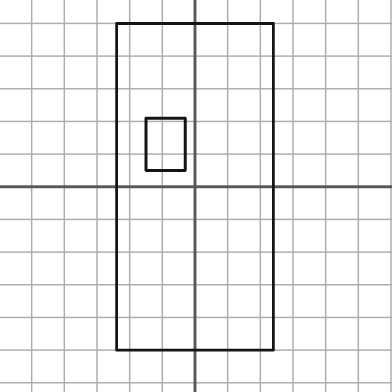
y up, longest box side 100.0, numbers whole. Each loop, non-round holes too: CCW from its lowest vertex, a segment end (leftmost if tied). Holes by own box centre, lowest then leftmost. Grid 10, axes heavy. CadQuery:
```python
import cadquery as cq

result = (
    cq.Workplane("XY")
    .moveTo(-24.0, -50.0)
    .lineTo(24.0, -50.0)
    .lineTo(24.0, 50.0)
    .lineTo(-24.0, 50.0)
    .close()
    .moveTo(-15.0, 5.0)
    .lineTo(-3.0, 5.0)
    .lineTo(-3.0, 21.0)
    .lineTo(-15.0, 21.0)
    .close()
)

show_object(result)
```